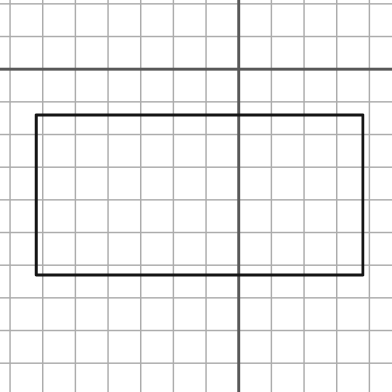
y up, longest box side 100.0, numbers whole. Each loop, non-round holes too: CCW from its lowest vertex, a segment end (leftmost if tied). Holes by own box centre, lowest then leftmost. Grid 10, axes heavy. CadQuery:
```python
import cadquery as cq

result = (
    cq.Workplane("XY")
    .moveTo(-62.0, -63.0)
    .lineTo(38.0, -63.0)
    .lineTo(38.0, -14.0)
    .lineTo(-62.0, -14.0)
    .close()
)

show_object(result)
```